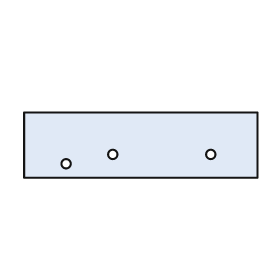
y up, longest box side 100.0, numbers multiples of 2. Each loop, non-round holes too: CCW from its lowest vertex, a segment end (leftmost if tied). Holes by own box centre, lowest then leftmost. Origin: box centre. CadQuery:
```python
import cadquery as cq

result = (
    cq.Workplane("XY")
    .moveTo(-50.0, -14.0)
    .lineTo(50.0, -14.0)
    .lineTo(50.0, 14.0)
    .lineTo(-50.0, 14.0)
    .close()
    .moveTo(-32.0, -8.0)
    .circle(2.0)
    .moveTo(-12.0, -4.0)
    .circle(2.0)
    .moveTo(30.0, -4.0)
    .circle(2.0)
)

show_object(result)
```